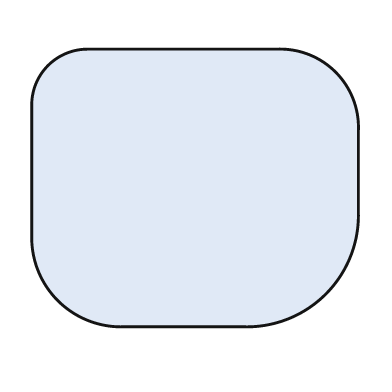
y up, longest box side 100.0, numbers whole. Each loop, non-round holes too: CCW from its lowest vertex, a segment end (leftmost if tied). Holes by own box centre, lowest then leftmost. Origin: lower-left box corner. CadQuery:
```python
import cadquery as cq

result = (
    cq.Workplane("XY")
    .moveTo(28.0, 0.0)
    .lineTo(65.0, 0.0)
    .threePointArc((90.0, 10.0), (100.0, 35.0))
    .lineTo(100.0, 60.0)
    .threePointArc((93.0, 78.0), (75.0, 85.0))
    .lineTo(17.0, 85.0)
    .threePointArc((5.0, 80.0), (0.0, 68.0))
    .lineTo(0.0, 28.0)
    .threePointArc((8.0, 8.0), (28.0, 0.0))
    .close()
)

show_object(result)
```